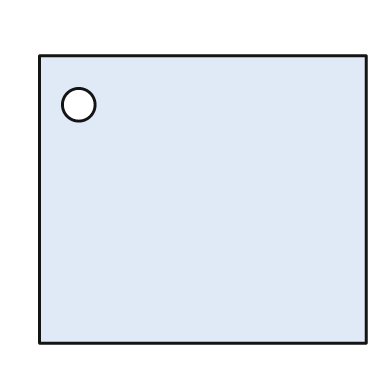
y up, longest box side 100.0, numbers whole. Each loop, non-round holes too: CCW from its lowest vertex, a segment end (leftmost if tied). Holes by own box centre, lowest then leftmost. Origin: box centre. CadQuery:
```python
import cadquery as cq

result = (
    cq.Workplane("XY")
    .moveTo(-50.0, -44.0)
    .lineTo(50.0, -44.0)
    .lineTo(50.0, 44.0)
    .lineTo(-50.0, 44.0)
    .close()
    .moveTo(-38.0, 29.0)
    .circle(5.0)
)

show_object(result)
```